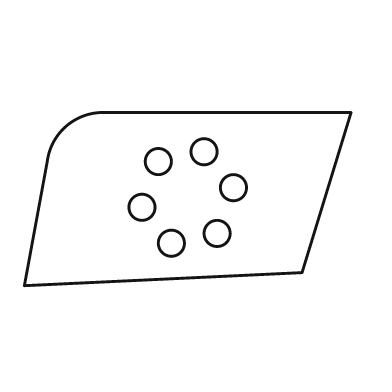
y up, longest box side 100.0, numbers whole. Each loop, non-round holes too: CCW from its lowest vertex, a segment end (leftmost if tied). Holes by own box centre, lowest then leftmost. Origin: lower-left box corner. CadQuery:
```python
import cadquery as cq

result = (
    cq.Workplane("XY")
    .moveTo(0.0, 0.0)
    .lineTo(85.0, 4.0)
    .lineTo(100.0, 53.0)
    .lineTo(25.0, 53.0)
    .threePointArc((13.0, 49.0), (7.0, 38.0))
    .close()
    .moveTo(45.0, 13.0)
    .circle(4.0)
    .moveTo(59.0, 16.0)
    .circle(4.0)
    .moveTo(36.0, 24.0)
    .circle(4.0)
    .moveTo(64.0, 30.0)
    .circle(4.0)
    .moveTo(41.0, 38.0)
    .circle(4.0)
    .moveTo(55.0, 41.0)
    .circle(4.0)
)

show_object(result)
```